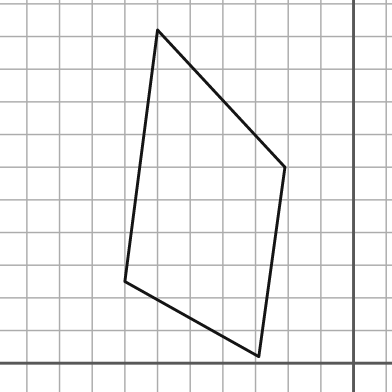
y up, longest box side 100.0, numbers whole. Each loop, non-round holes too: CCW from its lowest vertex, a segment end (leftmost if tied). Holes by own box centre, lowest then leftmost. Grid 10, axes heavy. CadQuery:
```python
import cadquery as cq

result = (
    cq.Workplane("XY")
    .moveTo(-29.0, 2.0)
    .lineTo(-21.0, 60.0)
    .lineTo(-60.0, 102.0)
    .lineTo(-70.0, 25.0)
    .close()
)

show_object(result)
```